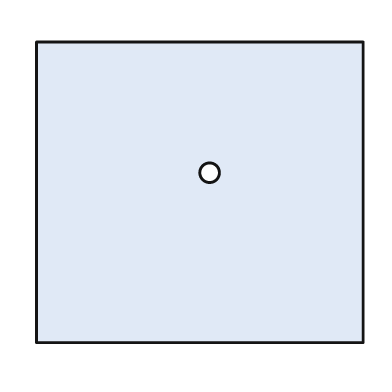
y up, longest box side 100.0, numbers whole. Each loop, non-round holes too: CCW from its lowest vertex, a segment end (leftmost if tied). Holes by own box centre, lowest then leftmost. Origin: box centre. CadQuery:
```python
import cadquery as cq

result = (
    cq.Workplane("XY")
    .moveTo(-50.0, -46.0)
    .lineTo(50.0, -46.0)
    .lineTo(50.0, 46.0)
    .lineTo(-50.0, 46.0)
    .close()
    .moveTo(3.0, 6.0)
    .circle(3.0)
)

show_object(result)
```